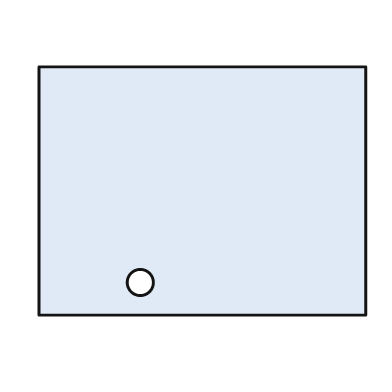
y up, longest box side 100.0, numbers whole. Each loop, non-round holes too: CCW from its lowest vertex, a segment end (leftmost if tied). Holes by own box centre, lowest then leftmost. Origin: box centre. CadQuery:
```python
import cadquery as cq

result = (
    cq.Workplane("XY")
    .moveTo(-50.0, -38.0)
    .lineTo(50.0, -38.0)
    .lineTo(50.0, 38.0)
    .lineTo(-50.0, 38.0)
    .close()
    .moveTo(-19.0, -28.0)
    .circle(4.0)
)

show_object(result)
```